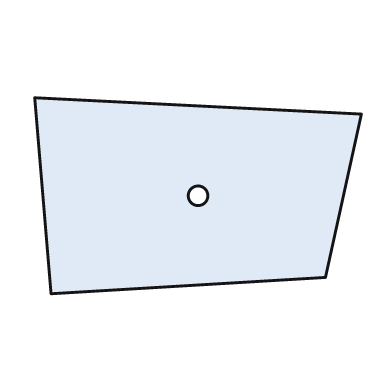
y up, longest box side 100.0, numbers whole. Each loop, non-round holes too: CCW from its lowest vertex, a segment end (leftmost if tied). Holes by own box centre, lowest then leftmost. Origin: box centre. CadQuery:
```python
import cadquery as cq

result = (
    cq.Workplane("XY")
    .moveTo(-45.0, -30.0)
    .lineTo(39.0, -25.0)
    .lineTo(50.0, 25.0)
    .lineTo(-50.0, 30.0)
    .close()
    .moveTo(0.0, 0.0)
    .circle(3.0)
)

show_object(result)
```